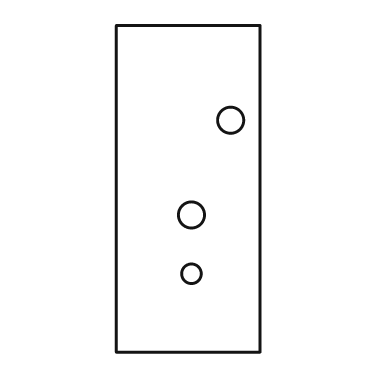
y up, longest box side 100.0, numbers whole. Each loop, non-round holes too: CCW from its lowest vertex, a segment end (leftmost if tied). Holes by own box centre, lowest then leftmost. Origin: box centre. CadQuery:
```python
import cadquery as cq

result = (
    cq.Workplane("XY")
    .moveTo(-22.0, -50.0)
    .lineTo(22.0, -50.0)
    .lineTo(22.0, 50.0)
    .lineTo(-22.0, 50.0)
    .close()
    .moveTo(1.0, -26.0)
    .circle(3.0)
    .moveTo(1.0, -8.0)
    .circle(4.0)
    .moveTo(13.0, 21.0)
    .circle(4.0)
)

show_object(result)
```